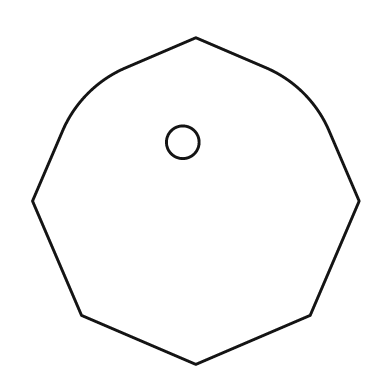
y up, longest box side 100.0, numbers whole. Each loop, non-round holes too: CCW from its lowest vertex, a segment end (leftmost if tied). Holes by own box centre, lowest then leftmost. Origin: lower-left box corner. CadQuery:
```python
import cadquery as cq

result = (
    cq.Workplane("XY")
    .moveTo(50.0, 0.0)
    .lineTo(85.0, 15.0)
    .lineTo(100.0, 50.0)
    .lineTo(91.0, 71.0)
    .threePointArc((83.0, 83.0), (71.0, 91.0))
    .lineTo(50.0, 100.0)
    .lineTo(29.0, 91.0)
    .threePointArc((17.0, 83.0), (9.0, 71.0))
    .lineTo(0.0, 50.0)
    .lineTo(15.0, 15.0)
    .close()
    .moveTo(46.0, 68.0)
    .circle(5.0)
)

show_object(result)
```